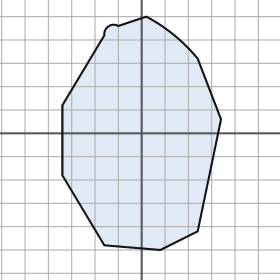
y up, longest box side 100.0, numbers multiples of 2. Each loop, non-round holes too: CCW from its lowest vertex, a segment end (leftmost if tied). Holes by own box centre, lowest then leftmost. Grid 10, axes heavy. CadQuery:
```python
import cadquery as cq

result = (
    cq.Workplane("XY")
    .moveTo(8.0, -50.0)
    .lineTo(24.0, -42.0)
    .lineTo(34.0, 6.0)
    .lineTo(24.0, 32.0)
    .threePointArc((14.0, 42.0), (2.0, 50.0))
    .lineTo(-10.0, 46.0)
    .threePointArc((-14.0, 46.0), (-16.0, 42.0))
    .lineTo(-34.0, 12.0)
    .lineTo(-34.0, -18.0)
    .lineTo(-16.0, -48.0)
    .close()
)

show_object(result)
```